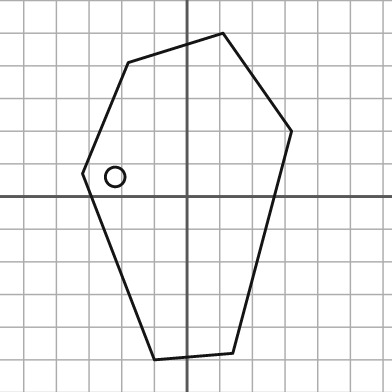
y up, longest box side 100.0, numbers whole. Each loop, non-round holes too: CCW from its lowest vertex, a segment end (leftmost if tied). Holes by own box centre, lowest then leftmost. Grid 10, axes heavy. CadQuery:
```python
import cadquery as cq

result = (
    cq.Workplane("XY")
    .moveTo(-10.0, -50.0)
    .lineTo(14.0, -48.0)
    .lineTo(32.0, 20.0)
    .lineTo(11.0, 50.0)
    .lineTo(-18.0, 41.0)
    .lineTo(-32.0, 7.0)
    .close()
    .moveTo(-22.0, 6.0)
    .circle(3.0)
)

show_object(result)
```